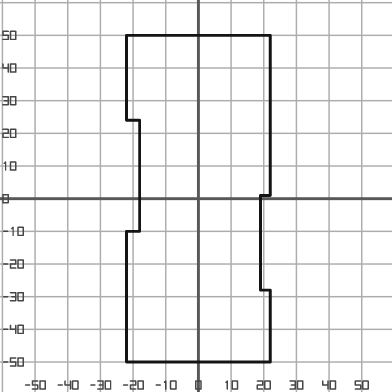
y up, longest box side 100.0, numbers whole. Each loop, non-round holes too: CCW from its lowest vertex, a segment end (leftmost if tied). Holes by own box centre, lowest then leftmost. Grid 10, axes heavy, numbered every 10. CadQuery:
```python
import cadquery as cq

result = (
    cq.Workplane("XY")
    .moveTo(-22.0, -50.0)
    .lineTo(22.0, -50.0)
    .lineTo(22.0, -28.0)
    .lineTo(19.0, -28.0)
    .lineTo(19.0, 1.0)
    .lineTo(22.0, 1.0)
    .lineTo(22.0, 50.0)
    .lineTo(-22.0, 50.0)
    .lineTo(-22.0, 24.0)
    .lineTo(-18.0, 24.0)
    .lineTo(-18.0, -10.0)
    .lineTo(-22.0, -10.0)
    .close()
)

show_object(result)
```